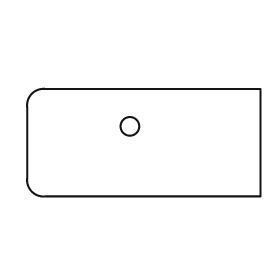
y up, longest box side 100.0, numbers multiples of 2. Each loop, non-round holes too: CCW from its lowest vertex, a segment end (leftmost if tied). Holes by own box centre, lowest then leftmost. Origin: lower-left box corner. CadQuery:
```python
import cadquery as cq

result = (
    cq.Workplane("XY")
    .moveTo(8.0, 0.0)
    .lineTo(100.0, 0.0)
    .lineTo(100.0, 46.0)
    .lineTo(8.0, 46.0)
    .threePointArc((2.0, 44.0), (0.0, 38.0))
    .lineTo(0.0, 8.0)
    .threePointArc((2.0, 2.0), (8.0, 0.0))
    .close()
    .moveTo(44.0, 30.0)
    .circle(4.0)
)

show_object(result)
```